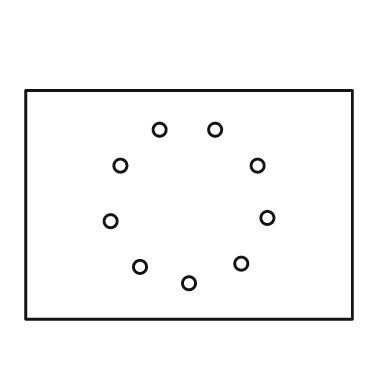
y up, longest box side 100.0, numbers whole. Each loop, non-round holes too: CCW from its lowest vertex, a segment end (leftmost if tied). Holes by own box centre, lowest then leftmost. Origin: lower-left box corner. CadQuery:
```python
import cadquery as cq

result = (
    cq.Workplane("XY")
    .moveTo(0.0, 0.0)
    .lineTo(100.0, 0.0)
    .lineTo(100.0, 70.0)
    .lineTo(0.0, 70.0)
    .close()
    .moveTo(50.0, 11.0)
    .circle(2.0)
    .moveTo(35.0, 16.0)
    .circle(2.0)
    .moveTo(66.0, 17.0)
    .circle(2.0)
    .moveTo(26.0, 30.0)
    .circle(2.0)
    .moveTo(74.0, 31.0)
    .circle(2.0)
    .moveTo(29.0, 47.0)
    .circle(2.0)
    .moveTo(71.0, 47.0)
    .circle(2.0)
    .moveTo(41.0, 58.0)
    .circle(2.0)
    .moveTo(58.0, 58.0)
    .circle(2.0)
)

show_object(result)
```